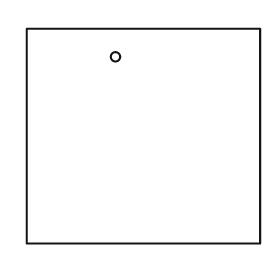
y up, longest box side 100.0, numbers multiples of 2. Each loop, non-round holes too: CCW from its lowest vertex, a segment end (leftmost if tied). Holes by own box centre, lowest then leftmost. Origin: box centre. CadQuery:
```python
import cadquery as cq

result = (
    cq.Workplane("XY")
    .moveTo(-50.0, -46.0)
    .lineTo(50.0, -46.0)
    .lineTo(50.0, 46.0)
    .lineTo(-50.0, 46.0)
    .close()
    .moveTo(-12.0, 34.0)
    .circle(2.0)
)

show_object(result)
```